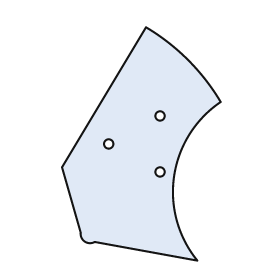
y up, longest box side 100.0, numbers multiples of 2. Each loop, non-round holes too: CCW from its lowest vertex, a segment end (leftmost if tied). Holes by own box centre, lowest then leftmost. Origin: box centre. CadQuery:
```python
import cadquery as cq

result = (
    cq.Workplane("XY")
    .moveTo(24.0, -50.0)
    .threePointArc((14.0, -14.0), (34.0, 18.0))
    .threePointArc((20.0, 36.0), (2.0, 50.0))
    .lineTo(-34.0, -10.0)
    .lineTo(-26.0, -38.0)
    .threePointArc((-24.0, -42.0), (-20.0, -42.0))
    .close()
    .moveTo(8.0, -12.0)
    .circle(2.0)
    .moveTo(-14.0, 0.0)
    .circle(2.0)
    .moveTo(8.0, 12.0)
    .circle(2.0)
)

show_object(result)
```